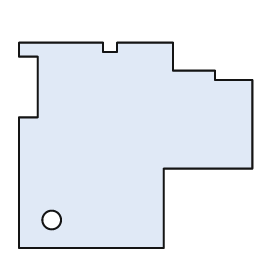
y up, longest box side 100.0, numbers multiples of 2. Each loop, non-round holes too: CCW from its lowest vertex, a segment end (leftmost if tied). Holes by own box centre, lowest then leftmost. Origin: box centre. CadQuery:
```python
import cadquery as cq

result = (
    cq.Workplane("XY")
    .moveTo(-50.0, -44.0)
    .lineTo(12.0, -44.0)
    .lineTo(12.0, -10.0)
    .lineTo(50.0, -10.0)
    .lineTo(50.0, 28.0)
    .lineTo(34.0, 28.0)
    .lineTo(34.0, 32.0)
    .lineTo(16.0, 32.0)
    .lineTo(16.0, 44.0)
    .lineTo(-8.0, 44.0)
    .lineTo(-8.0, 40.0)
    .lineTo(-14.0, 40.0)
    .lineTo(-14.0, 44.0)
    .lineTo(-50.0, 44.0)
    .lineTo(-50.0, 38.0)
    .lineTo(-42.0, 38.0)
    .lineTo(-42.0, 12.0)
    .lineTo(-50.0, 12.0)
    .close()
    .moveTo(-36.0, -32.0)
    .circle(4.0)
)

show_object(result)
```